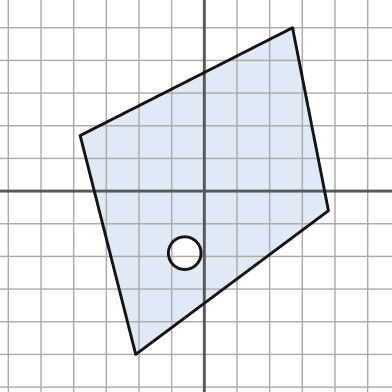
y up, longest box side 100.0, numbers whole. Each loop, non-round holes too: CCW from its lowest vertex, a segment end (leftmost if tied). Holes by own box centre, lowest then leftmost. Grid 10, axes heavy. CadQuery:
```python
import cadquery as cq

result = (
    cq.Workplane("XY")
    .moveTo(-21.0, -50.0)
    .lineTo(38.0, -6.0)
    .lineTo(27.0, 50.0)
    .lineTo(-38.0, 17.0)
    .close()
    .moveTo(-6.0, -19.0)
    .circle(5.0)
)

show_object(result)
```